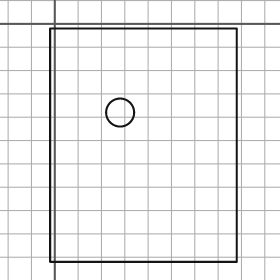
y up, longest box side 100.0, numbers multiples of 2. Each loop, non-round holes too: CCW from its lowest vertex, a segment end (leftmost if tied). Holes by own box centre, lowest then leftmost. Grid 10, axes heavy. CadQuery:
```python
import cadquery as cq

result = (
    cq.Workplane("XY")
    .moveTo(-2.0, -102.0)
    .lineTo(78.0, -102.0)
    .lineTo(78.0, -2.0)
    .lineTo(-2.0, -2.0)
    .close()
    .moveTo(28.0, -38.0)
    .circle(6.0)
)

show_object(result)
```